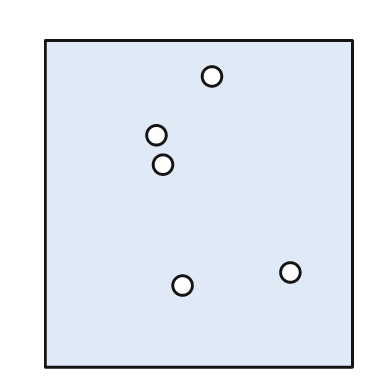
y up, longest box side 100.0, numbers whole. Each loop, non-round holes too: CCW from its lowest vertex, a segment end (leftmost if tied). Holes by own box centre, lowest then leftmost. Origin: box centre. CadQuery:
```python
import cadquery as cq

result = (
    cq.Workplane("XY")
    .moveTo(-47.0, -50.0)
    .lineTo(47.0, -50.0)
    .lineTo(47.0, 50.0)
    .lineTo(-47.0, 50.0)
    .close()
    .moveTo(-5.0, -25.0)
    .circle(3.0)
    .moveTo(28.0, -21.0)
    .circle(3.0)
    .moveTo(-11.0, 12.0)
    .circle(3.0)
    .moveTo(-13.0, 21.0)
    .circle(3.0)
    .moveTo(4.0, 39.0)
    .circle(3.0)
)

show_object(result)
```